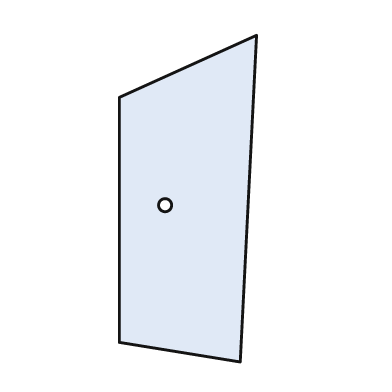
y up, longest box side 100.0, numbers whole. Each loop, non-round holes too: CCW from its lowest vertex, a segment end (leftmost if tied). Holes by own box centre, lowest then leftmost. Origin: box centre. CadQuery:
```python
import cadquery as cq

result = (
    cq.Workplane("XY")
    .moveTo(16.0, -50.0)
    .lineTo(21.0, 50.0)
    .lineTo(-21.0, 31.0)
    .lineTo(-21.0, -44.0)
    .close()
    .moveTo(-7.0, -2.0)
    .circle(2.0)
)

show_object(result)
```